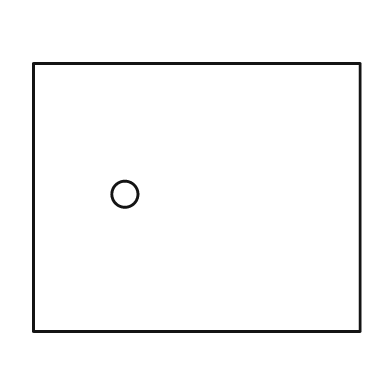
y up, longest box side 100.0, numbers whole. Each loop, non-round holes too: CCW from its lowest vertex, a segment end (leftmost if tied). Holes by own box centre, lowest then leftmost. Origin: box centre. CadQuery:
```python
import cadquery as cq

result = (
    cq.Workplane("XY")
    .moveTo(-50.0, -41.0)
    .lineTo(50.0, -41.0)
    .lineTo(50.0, 41.0)
    .lineTo(-50.0, 41.0)
    .close()
    .moveTo(-22.0, 1.0)
    .circle(4.0)
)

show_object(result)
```